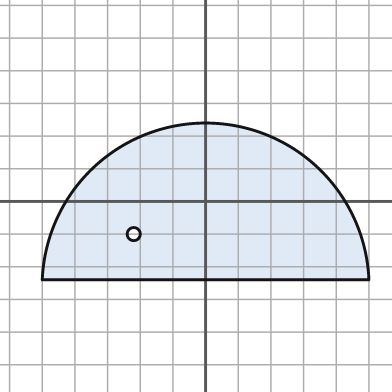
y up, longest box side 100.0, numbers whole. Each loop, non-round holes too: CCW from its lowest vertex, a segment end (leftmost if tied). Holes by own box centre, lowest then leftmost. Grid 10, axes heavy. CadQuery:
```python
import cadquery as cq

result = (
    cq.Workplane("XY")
    .moveTo(-50.0, -24.0)
    .lineTo(50.0, -24.0)
    .threePointArc((0.0, 24.0), (-50.0, -24.0))
    .close()
    .moveTo(-22.0, -10.0)
    .circle(2.0)
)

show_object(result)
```